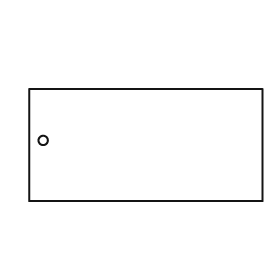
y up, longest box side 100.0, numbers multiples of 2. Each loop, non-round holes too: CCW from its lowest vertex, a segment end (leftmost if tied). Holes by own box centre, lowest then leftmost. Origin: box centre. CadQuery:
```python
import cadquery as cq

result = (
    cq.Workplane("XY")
    .moveTo(-50.0, -24.0)
    .lineTo(50.0, -24.0)
    .lineTo(50.0, 24.0)
    .lineTo(-50.0, 24.0)
    .close()
    .moveTo(-44.0, 2.0)
    .circle(2.0)
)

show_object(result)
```